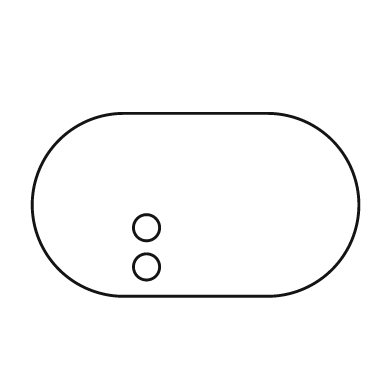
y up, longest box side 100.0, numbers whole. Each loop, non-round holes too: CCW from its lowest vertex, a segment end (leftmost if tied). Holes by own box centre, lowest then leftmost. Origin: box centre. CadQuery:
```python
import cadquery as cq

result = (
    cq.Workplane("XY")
    .moveTo(-22.0, -28.0)
    .lineTo(22.0, -28.0)
    .threePointArc((50.0, 0.0), (22.0, 28.0))
    .lineTo(-22.0, 28.0)
    .threePointArc((-50.0, 0.0), (-22.0, -28.0))
    .close()
    .moveTo(-15.0, -19.0)
    .circle(4.0)
    .moveTo(-15.0, -7.0)
    .circle(4.0)
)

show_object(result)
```